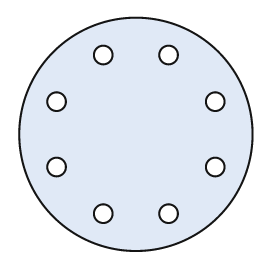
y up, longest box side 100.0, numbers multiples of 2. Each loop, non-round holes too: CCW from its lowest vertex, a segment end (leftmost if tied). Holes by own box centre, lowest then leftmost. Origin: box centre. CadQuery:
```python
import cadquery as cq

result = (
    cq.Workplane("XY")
    .moveTo(0.0, 0.0)
    .circle(50.0)
    .moveTo(-14.0, -34.0)
    .circle(4.0)
    .moveTo(14.0, -34.0)
    .circle(4.0)
    .moveTo(-34.0, -14.0)
    .circle(4.0)
    .moveTo(34.0, -14.0)
    .circle(4.0)
    .moveTo(-34.0, 14.0)
    .circle(4.0)
    .moveTo(34.0, 14.0)
    .circle(4.0)
    .moveTo(-14.0, 34.0)
    .circle(4.0)
    .moveTo(14.0, 34.0)
    .circle(4.0)
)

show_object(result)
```